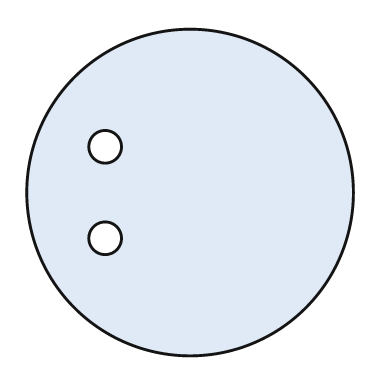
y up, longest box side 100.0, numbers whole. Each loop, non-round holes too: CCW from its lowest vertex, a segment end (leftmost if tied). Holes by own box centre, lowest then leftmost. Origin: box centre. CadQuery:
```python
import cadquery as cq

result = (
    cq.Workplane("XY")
    .moveTo(0.0, 0.0)
    .circle(50.0)
    .moveTo(-26.0, -14.0)
    .circle(5.0)
    .moveTo(-26.0, 14.0)
    .circle(5.0)
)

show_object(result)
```